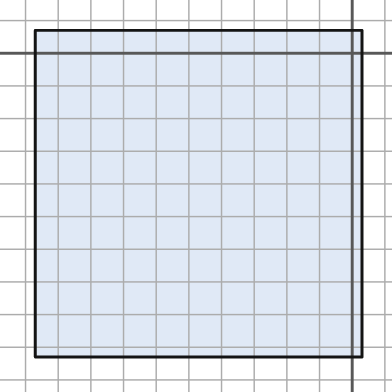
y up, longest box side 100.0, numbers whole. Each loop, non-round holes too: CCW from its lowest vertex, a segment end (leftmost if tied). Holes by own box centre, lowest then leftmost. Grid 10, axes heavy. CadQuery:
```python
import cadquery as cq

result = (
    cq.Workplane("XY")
    .moveTo(-97.0, -93.0)
    .lineTo(3.0, -93.0)
    .lineTo(3.0, 7.0)
    .lineTo(-97.0, 7.0)
    .close()
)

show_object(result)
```